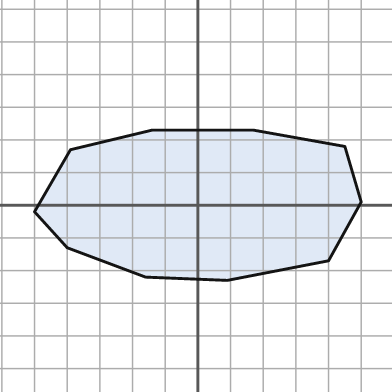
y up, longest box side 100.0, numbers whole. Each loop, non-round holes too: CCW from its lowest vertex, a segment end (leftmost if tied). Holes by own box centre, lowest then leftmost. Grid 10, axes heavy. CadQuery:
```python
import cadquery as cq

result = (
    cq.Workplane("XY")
    .moveTo(9.0, -23.0)
    .lineTo(40.0, -17.0)
    .lineTo(50.0, 1.0)
    .lineTo(45.0, 18.0)
    .lineTo(17.0, 23.0)
    .lineTo(-14.0, 23.0)
    .lineTo(-39.0, 17.0)
    .lineTo(-50.0, -2.0)
    .lineTo(-40.0, -13.0)
    .lineTo(-16.0, -22.0)
    .close()
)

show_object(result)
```